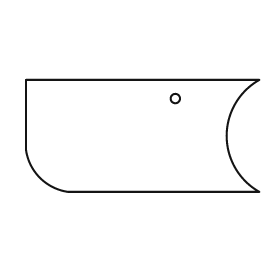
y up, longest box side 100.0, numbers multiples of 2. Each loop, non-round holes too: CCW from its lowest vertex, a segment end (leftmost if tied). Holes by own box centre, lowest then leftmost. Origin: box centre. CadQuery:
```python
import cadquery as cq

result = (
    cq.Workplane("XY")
    .moveTo(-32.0, -24.0)
    .lineTo(50.0, -24.0)
    .threePointArc((36.0, 0.0), (50.0, 24.0))
    .lineTo(-50.0, 24.0)
    .lineTo(-50.0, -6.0)
    .threePointArc((-44.0, -18.0), (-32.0, -24.0))
    .close()
    .moveTo(14.0, 16.0)
    .circle(2.0)
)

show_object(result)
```